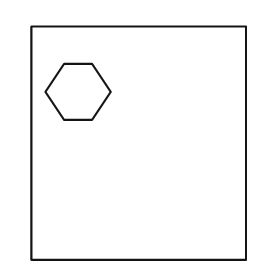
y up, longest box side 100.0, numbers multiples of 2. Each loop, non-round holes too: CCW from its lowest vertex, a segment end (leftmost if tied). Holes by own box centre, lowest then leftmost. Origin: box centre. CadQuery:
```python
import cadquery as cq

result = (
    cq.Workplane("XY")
    .moveTo(-46.0, -50.0)
    .lineTo(46.0, -50.0)
    .lineTo(46.0, 50.0)
    .lineTo(-46.0, 50.0)
    .close()
    .moveTo(-32.0, 10.0)
    .lineTo(-20.0, 10.0)
    .lineTo(-12.0, 22.0)
    .lineTo(-20.0, 34.0)
    .lineTo(-32.0, 34.0)
    .lineTo(-40.0, 22.0)
    .close()
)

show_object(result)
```